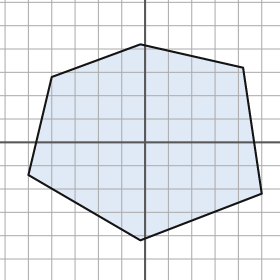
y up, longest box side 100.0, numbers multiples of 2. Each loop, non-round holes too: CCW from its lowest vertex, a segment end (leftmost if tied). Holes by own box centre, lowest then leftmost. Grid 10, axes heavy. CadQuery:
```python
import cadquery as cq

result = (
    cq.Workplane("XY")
    .moveTo(-2.0, -42.0)
    .lineTo(50.0, -22.0)
    .lineTo(42.0, 32.0)
    .lineTo(-2.0, 42.0)
    .lineTo(-40.0, 28.0)
    .lineTo(-50.0, -14.0)
    .close()
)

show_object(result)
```